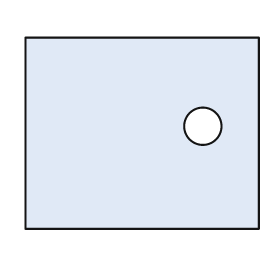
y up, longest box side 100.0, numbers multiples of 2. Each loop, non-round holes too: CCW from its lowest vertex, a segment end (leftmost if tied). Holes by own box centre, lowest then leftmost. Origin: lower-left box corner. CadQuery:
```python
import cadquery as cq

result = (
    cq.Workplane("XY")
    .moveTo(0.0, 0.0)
    .lineTo(100.0, 0.0)
    .lineTo(100.0, 82.0)
    .lineTo(0.0, 82.0)
    .close()
    .moveTo(76.0, 44.0)
    .circle(8.0)
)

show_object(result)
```